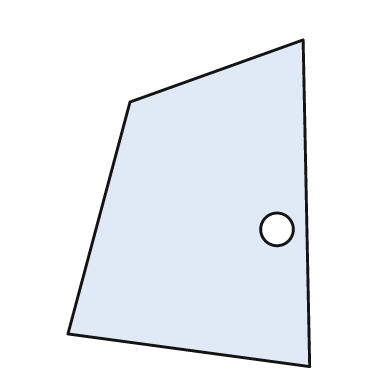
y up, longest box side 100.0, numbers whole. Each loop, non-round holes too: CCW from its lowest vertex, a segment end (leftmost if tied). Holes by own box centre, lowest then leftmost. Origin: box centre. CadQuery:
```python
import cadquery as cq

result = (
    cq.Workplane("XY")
    .moveTo(37.0, -50.0)
    .lineTo(35.0, 50.0)
    .lineTo(-18.0, 31.0)
    .lineTo(-37.0, -40.0)
    .close()
    .moveTo(27.0, -8.0)
    .circle(5.0)
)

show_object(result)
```